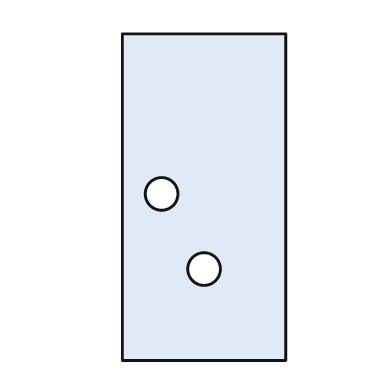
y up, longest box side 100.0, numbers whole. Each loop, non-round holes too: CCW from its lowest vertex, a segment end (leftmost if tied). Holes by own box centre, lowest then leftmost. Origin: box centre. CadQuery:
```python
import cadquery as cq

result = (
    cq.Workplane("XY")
    .moveTo(-25.0, -50.0)
    .lineTo(25.0, -50.0)
    .lineTo(25.0, 50.0)
    .lineTo(-25.0, 50.0)
    .close()
    .moveTo(0.0, -22.0)
    .circle(5.0)
    .moveTo(-13.0, 1.0)
    .circle(5.0)
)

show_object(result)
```